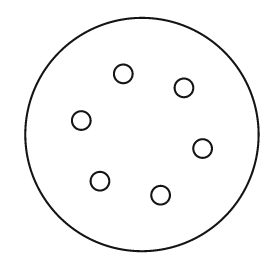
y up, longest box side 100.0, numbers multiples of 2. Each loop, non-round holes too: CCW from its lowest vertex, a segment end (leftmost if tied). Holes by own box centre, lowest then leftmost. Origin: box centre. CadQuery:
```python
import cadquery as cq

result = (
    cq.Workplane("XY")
    .moveTo(0.0, 0.0)
    .circle(50.0)
    .moveTo(8.0, -26.0)
    .circle(4.0)
    .moveTo(-18.0, -20.0)
    .circle(4.0)
    .moveTo(26.0, -6.0)
    .circle(4.0)
    .moveTo(-26.0, 6.0)
    .circle(4.0)
    .moveTo(18.0, 20.0)
    .circle(4.0)
    .moveTo(-8.0, 26.0)
    .circle(4.0)
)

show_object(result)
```